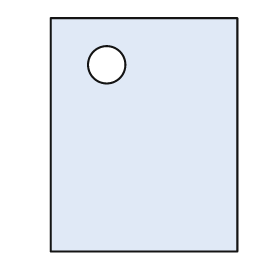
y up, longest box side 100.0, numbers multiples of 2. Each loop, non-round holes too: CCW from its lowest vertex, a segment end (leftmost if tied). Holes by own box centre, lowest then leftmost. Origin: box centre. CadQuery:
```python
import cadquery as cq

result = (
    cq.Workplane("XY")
    .moveTo(-40.0, -50.0)
    .lineTo(40.0, -50.0)
    .lineTo(40.0, 50.0)
    .lineTo(-40.0, 50.0)
    .close()
    .moveTo(-16.0, 30.0)
    .circle(8.0)
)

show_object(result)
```